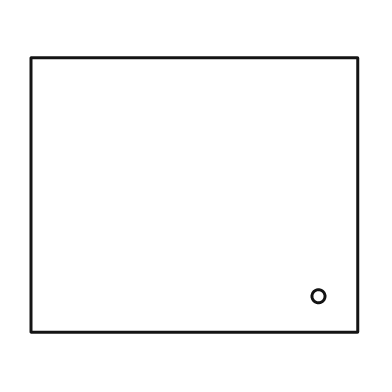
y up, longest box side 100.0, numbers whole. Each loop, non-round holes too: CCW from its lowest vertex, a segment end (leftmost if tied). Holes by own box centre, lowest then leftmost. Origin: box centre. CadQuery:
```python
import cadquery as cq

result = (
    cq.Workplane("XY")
    .moveTo(-50.0, -42.0)
    .lineTo(50.0, -42.0)
    .lineTo(50.0, 42.0)
    .lineTo(-50.0, 42.0)
    .close()
    .moveTo(38.0, -31.0)
    .circle(2.0)
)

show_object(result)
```